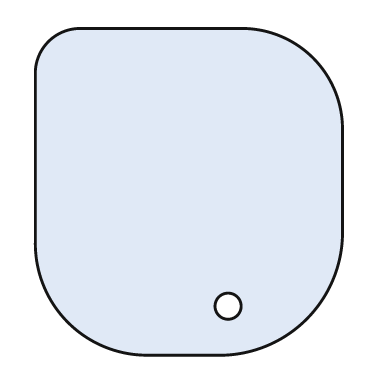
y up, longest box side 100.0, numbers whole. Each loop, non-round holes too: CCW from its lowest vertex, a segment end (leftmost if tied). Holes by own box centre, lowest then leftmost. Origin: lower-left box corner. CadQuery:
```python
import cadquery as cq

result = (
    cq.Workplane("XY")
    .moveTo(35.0, 0.0)
    .lineTo(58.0, 0.0)
    .threePointArc((83.0, 11.0), (94.0, 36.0))
    .lineTo(94.0, 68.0)
    .threePointArc((85.0, 91.0), (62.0, 100.0))
    .lineTo(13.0, 100.0)
    .threePointArc((4.0, 96.0), (0.0, 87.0))
    .lineTo(0.0, 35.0)
    .threePointArc((10.0, 10.0), (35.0, 0.0))
    .close()
    .moveTo(59.0, 15.0)
    .circle(4.0)
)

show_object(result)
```